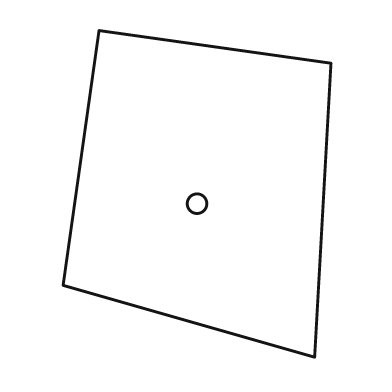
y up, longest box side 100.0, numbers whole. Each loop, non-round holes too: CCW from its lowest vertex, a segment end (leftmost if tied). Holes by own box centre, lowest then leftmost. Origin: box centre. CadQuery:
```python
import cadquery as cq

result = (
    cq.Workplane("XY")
    .moveTo(36.0, -50.0)
    .lineTo(41.0, 40.0)
    .lineTo(-30.0, 50.0)
    .lineTo(-41.0, -28.0)
    .close()
    .moveTo(0.0, -3.0)
    .circle(3.0)
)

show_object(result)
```